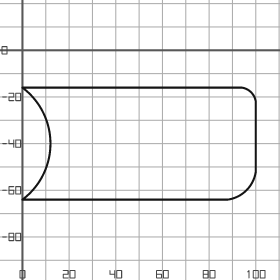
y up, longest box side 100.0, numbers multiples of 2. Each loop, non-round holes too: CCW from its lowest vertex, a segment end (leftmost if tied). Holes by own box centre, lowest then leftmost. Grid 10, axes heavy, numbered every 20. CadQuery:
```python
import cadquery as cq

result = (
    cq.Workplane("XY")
    .moveTo(0.0, -64.0)
    .lineTo(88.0, -64.0)
    .threePointArc((96.0, -60.0), (100.0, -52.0))
    .lineTo(100.0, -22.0)
    .threePointArc((98.0, -18.0), (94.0, -16.0))
    .lineTo(0.0, -16.0)
    .threePointArc((12.0, -40.0), (0.0, -64.0))
    .close()
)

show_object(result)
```